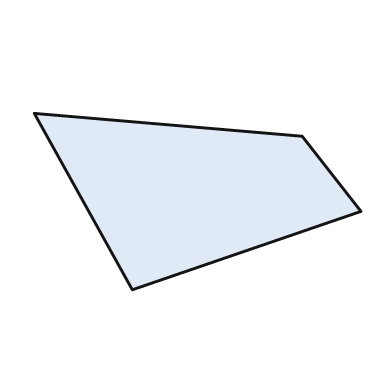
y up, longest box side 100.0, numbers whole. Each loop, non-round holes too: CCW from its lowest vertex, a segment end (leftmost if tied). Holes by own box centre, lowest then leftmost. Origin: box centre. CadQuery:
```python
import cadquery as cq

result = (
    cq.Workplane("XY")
    .moveTo(-20.0, -27.0)
    .lineTo(50.0, -3.0)
    .lineTo(32.0, 20.0)
    .lineTo(-50.0, 27.0)
    .close()
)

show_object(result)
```